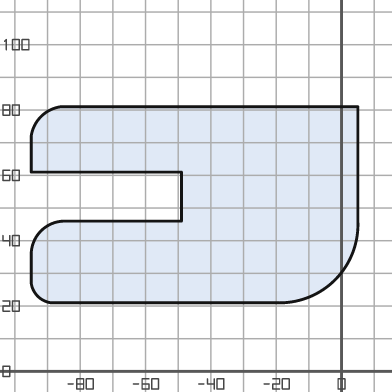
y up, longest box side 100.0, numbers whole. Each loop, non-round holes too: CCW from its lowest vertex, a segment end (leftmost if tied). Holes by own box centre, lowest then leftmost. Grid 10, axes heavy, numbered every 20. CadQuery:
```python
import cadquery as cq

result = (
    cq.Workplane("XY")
    .moveTo(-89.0, 21.0)
    .lineTo(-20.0, 21.0)
    .threePointArc((-2.0, 28.0), (5.0, 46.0))
    .lineTo(5.0, 81.0)
    .lineTo(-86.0, 81.0)
    .threePointArc((-92.0, 78.0), (-95.0, 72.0))
    .lineTo(-95.0, 61.0)
    .lineTo(-49.0, 61.0)
    .lineTo(-49.0, 46.0)
    .lineTo(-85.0, 46.0)
    .threePointArc((-92.0, 43.0), (-95.0, 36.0))
    .lineTo(-95.0, 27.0)
    .threePointArc((-93.0, 23.0), (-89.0, 21.0))
    .close()
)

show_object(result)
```